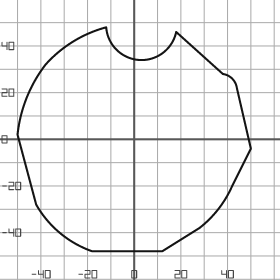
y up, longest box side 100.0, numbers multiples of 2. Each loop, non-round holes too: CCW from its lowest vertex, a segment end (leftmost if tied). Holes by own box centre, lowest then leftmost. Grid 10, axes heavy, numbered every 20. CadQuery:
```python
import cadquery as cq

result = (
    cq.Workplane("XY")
    .moveTo(-18.0, -48.0)
    .lineTo(12.0, -48.0)
    .lineTo(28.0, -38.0)
    .threePointArc((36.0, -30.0), (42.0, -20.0))
    .lineTo(50.0, -4.0)
    .lineTo(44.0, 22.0)
    .threePointArc((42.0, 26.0), (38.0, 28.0))
    .lineTo(18.0, 46.0)
    .threePointArc((2.0, 34.0), (-12.0, 48.0))
    .threePointArc((-26.0, 42.0), (-38.0, 32.0))
    .threePointArc((-46.0, 18.0), (-50.0, 2.0))
    .lineTo(-42.0, -28.0)
    .threePointArc((-32.0, -40.0), (-18.0, -48.0))
    .close()
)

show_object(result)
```